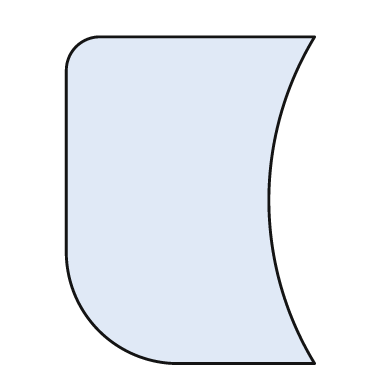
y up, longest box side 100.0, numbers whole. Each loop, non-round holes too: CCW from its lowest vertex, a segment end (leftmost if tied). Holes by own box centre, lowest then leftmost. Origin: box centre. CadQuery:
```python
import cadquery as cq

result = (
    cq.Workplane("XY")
    .moveTo(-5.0, -50.0)
    .lineTo(38.0, -50.0)
    .threePointArc((24.0, 0.0), (38.0, 50.0))
    .lineTo(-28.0, 50.0)
    .threePointArc((-35.0, 47.0), (-38.0, 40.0))
    .lineTo(-38.0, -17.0)
    .threePointArc((-28.0, -40.0), (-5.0, -50.0))
    .close()
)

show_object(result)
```